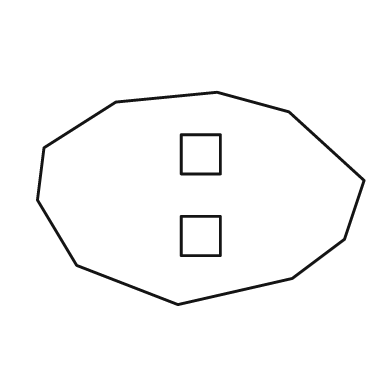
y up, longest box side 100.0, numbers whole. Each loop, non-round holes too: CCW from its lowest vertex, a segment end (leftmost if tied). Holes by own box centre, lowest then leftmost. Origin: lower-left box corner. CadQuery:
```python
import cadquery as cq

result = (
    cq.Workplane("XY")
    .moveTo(43.0, 0.0)
    .lineTo(78.0, 8.0)
    .lineTo(94.0, 20.0)
    .lineTo(100.0, 38.0)
    .lineTo(77.0, 59.0)
    .lineTo(55.0, 65.0)
    .lineTo(24.0, 62.0)
    .lineTo(2.0, 48.0)
    .lineTo(0.0, 32.0)
    .lineTo(12.0, 12.0)
    .close()
    .moveTo(44.0, 15.0)
    .lineTo(56.0, 15.0)
    .lineTo(56.0, 27.0)
    .lineTo(44.0, 27.0)
    .close()
    .moveTo(44.0, 40.0)
    .lineTo(56.0, 40.0)
    .lineTo(56.0, 52.0)
    .lineTo(44.0, 52.0)
    .close()
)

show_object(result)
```